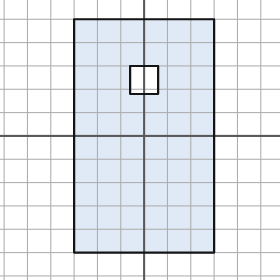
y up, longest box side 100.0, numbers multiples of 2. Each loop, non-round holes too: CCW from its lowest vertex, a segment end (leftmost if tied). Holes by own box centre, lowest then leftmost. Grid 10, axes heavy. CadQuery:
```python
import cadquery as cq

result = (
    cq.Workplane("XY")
    .moveTo(-30.0, -50.0)
    .lineTo(30.0, -50.0)
    .lineTo(30.0, 50.0)
    .lineTo(-30.0, 50.0)
    .close()
    .moveTo(-6.0, 18.0)
    .lineTo(6.0, 18.0)
    .lineTo(6.0, 30.0)
    .lineTo(-6.0, 30.0)
    .close()
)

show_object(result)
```